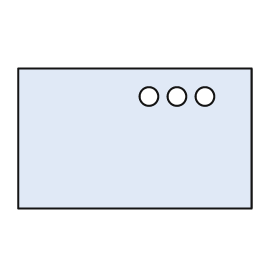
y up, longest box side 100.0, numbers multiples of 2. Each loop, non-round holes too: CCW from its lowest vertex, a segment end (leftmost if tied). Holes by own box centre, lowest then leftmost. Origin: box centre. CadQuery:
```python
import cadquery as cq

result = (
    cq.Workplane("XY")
    .moveTo(-50.0, -30.0)
    .lineTo(50.0, -30.0)
    .lineTo(50.0, 30.0)
    .lineTo(-50.0, 30.0)
    .close()
    .moveTo(6.0, 18.0)
    .circle(4.0)
    .moveTo(18.0, 18.0)
    .circle(4.0)
    .moveTo(30.0, 18.0)
    .circle(4.0)
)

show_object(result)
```